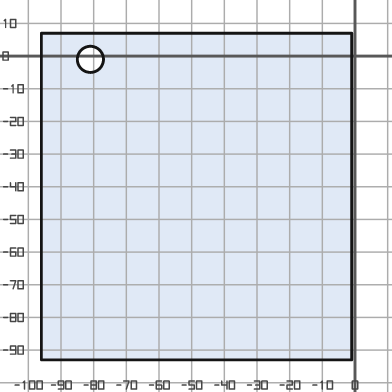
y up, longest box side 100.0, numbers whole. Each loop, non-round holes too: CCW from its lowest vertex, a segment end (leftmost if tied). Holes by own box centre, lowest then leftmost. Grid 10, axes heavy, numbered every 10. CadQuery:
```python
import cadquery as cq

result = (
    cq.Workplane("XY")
    .moveTo(-96.0, -93.0)
    .lineTo(-1.0, -93.0)
    .lineTo(-1.0, 7.0)
    .lineTo(-96.0, 7.0)
    .close()
    .moveTo(-81.0, -1.0)
    .circle(4.0)
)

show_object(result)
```